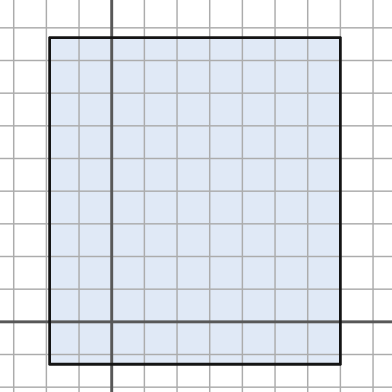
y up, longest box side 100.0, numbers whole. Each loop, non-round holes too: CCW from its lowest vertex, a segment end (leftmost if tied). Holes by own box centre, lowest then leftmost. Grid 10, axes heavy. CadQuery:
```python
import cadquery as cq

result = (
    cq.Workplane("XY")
    .moveTo(-19.0, -13.0)
    .lineTo(70.0, -13.0)
    .lineTo(70.0, 87.0)
    .lineTo(-19.0, 87.0)
    .close()
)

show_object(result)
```